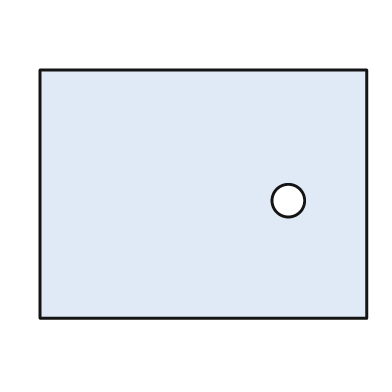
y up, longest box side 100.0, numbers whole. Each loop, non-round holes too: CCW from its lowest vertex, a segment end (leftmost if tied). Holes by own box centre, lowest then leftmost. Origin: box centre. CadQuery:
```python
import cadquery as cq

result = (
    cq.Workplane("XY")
    .moveTo(-50.0, -38.0)
    .lineTo(50.0, -38.0)
    .lineTo(50.0, 38.0)
    .lineTo(-50.0, 38.0)
    .close()
    .moveTo(26.0, -2.0)
    .circle(5.0)
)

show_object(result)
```